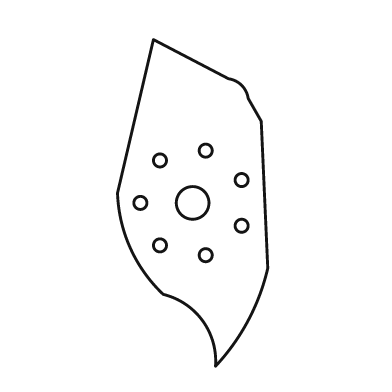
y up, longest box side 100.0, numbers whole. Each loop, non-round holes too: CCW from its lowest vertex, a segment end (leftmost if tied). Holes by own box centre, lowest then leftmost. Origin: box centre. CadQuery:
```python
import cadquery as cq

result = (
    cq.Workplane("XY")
    .moveTo(7.0, -50.0)
    .threePointArc((17.0, -36.0), (23.0, -20.0))
    .lineTo(21.0, 25.0)
    .lineTo(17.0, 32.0)
    .threePointArc((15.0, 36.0), (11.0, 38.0))
    .lineTo(-12.0, 50.0)
    .lineTo(-23.0, 3.0)
    .threePointArc((-19.0, -14.0), (-9.0, -28.0))
    .threePointArc((3.0, -36.0), (7.0, -50.0))
    .close()
    .moveTo(4.0, -16.0)
    .circle(2.0)
    .moveTo(-10.0, -13.0)
    .circle(2.0)
    .moveTo(15.0, -7.0)
    .circle(2.0)
    .moveTo(-16.0, 0.0)
    .circle(2.0)
    .moveTo(0.0, 0.0)
    .circle(5.0)
    .moveTo(15.0, 7.0)
    .circle(2.0)
    .moveTo(-10.0, 13.0)
    .circle(2.0)
    .moveTo(4.0, 16.0)
    .circle(2.0)
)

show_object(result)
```